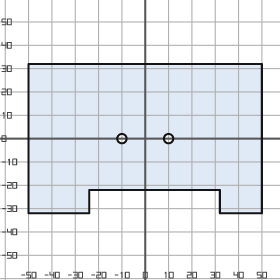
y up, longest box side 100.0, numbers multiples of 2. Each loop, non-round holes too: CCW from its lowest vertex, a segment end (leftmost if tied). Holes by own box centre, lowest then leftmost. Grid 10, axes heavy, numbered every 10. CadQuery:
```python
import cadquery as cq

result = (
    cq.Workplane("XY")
    .moveTo(-50.0, -32.0)
    .lineTo(-24.0, -32.0)
    .lineTo(-24.0, -22.0)
    .lineTo(32.0, -22.0)
    .lineTo(32.0, -32.0)
    .lineTo(50.0, -32.0)
    .lineTo(50.0, 32.0)
    .lineTo(-50.0, 32.0)
    .close()
    .moveTo(-10.0, 0.0)
    .circle(2.0)
    .moveTo(10.0, 0.0)
    .circle(2.0)
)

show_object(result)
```